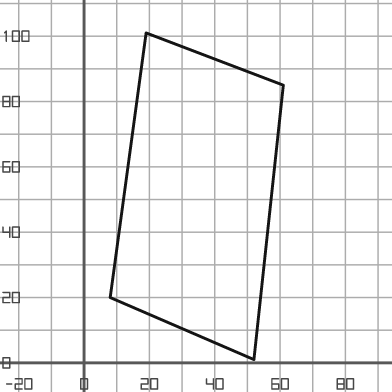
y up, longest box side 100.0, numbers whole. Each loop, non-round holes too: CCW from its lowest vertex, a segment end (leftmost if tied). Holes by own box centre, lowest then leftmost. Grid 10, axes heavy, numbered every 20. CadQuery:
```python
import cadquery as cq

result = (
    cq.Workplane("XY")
    .moveTo(52.0, 1.0)
    .lineTo(61.0, 85.0)
    .lineTo(19.0, 101.0)
    .lineTo(8.0, 20.0)
    .close()
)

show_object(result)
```